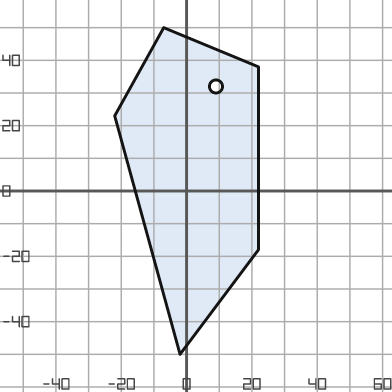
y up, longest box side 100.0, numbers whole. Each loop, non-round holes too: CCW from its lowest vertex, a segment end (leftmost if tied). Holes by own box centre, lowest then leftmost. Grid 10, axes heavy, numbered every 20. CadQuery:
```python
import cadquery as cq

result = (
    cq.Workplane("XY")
    .moveTo(-2.0, -50.0)
    .lineTo(22.0, -18.0)
    .lineTo(22.0, 38.0)
    .lineTo(-7.0, 50.0)
    .lineTo(-22.0, 23.0)
    .close()
    .moveTo(9.0, 32.0)
    .circle(2.0)
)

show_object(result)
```